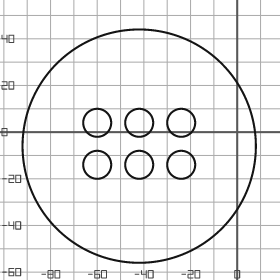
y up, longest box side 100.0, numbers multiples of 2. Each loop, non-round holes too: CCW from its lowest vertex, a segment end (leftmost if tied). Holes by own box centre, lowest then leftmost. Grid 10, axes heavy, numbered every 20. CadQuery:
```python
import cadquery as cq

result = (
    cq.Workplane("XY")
    .moveTo(-42.0, -6.0)
    .circle(50.0)
    .moveTo(-60.0, -14.0)
    .circle(6.0)
    .moveTo(-42.0, -14.0)
    .circle(6.0)
    .moveTo(-24.0, -14.0)
    .circle(6.0)
    .moveTo(-60.0, 4.0)
    .circle(6.0)
    .moveTo(-42.0, 4.0)
    .circle(6.0)
    .moveTo(-24.0, 4.0)
    .circle(6.0)
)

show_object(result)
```